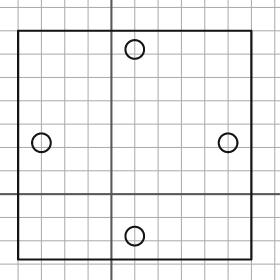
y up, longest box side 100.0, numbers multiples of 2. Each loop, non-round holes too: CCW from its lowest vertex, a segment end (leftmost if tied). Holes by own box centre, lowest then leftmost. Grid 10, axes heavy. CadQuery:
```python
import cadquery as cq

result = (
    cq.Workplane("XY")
    .moveTo(-40.0, -28.0)
    .lineTo(60.0, -28.0)
    .lineTo(60.0, 70.0)
    .lineTo(-40.0, 70.0)
    .close()
    .moveTo(10.0, -18.0)
    .circle(4.0)
    .moveTo(-30.0, 22.0)
    .circle(4.0)
    .moveTo(50.0, 22.0)
    .circle(4.0)
    .moveTo(10.0, 62.0)
    .circle(4.0)
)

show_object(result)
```